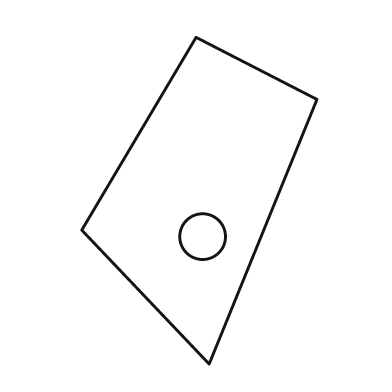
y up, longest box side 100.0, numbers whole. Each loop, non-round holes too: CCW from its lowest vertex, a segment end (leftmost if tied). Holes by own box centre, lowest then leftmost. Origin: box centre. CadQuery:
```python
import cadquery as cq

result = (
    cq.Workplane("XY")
    .moveTo(3.0, -50.0)
    .lineTo(36.0, 31.0)
    .lineTo(-1.0, 50.0)
    .lineTo(-36.0, -9.0)
    .close()
    .moveTo(1.0, -11.0)
    .circle(7.0)
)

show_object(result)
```